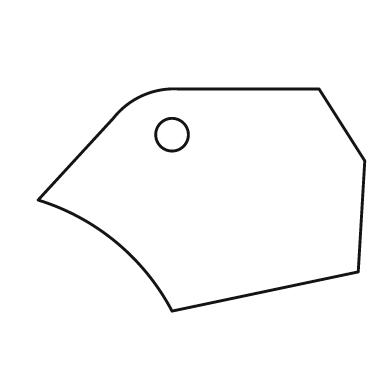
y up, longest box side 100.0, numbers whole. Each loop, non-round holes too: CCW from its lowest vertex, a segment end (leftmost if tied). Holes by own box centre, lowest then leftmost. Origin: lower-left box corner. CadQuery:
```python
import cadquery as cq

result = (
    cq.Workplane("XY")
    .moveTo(41.0, 0.0)
    .lineTo(98.0, 12.0)
    .lineTo(100.0, 46.0)
    .lineTo(86.0, 68.0)
    .lineTo(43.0, 68.0)
    .threePointArc((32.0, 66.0), (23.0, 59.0))
    .lineTo(0.0, 34.0)
    .threePointArc((24.0, 21.0), (41.0, 0.0))
    .close()
    .moveTo(41.0, 54.0)
    .circle(5.0)
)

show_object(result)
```